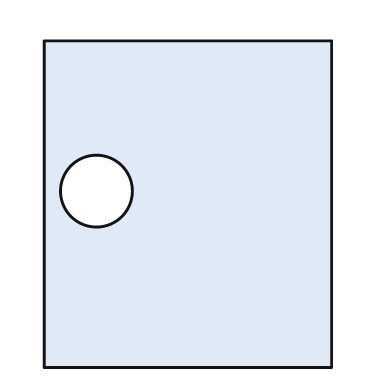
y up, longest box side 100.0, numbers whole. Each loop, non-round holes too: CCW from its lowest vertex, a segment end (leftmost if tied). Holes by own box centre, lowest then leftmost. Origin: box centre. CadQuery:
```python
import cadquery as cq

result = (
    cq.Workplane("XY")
    .moveTo(-44.0, -50.0)
    .lineTo(44.0, -50.0)
    .lineTo(44.0, 50.0)
    .lineTo(-44.0, 50.0)
    .close()
    .moveTo(-28.0, 4.0)
    .circle(11.0)
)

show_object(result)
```